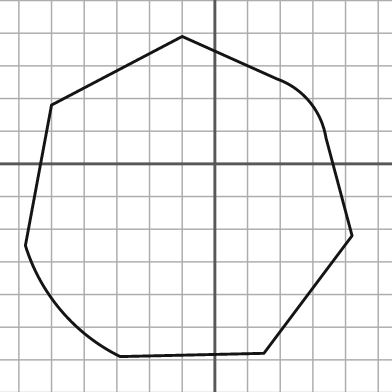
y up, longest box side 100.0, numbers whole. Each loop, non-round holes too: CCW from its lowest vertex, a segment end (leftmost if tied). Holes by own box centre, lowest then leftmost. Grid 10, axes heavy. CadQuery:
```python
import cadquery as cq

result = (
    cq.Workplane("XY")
    .moveTo(-29.0, -59.0)
    .lineTo(15.0, -58.0)
    .lineTo(42.0, -22.0)
    .lineTo(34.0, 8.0)
    .threePointArc((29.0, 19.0), (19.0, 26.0))
    .lineTo(-10.0, 39.0)
    .lineTo(-50.0, 18.0)
    .lineTo(-58.0, -25.0)
    .threePointArc((-47.0, -45.0), (-29.0, -59.0))
    .close()
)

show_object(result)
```